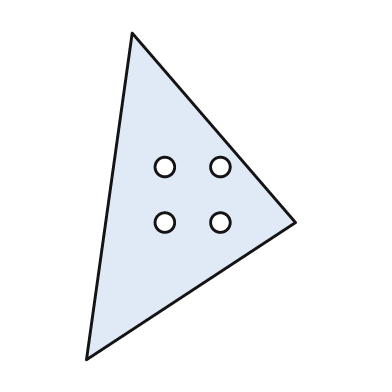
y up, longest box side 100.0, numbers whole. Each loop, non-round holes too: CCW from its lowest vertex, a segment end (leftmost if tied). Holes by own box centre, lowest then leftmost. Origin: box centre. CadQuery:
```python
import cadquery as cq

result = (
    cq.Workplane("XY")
    .moveTo(-32.0, -50.0)
    .lineTo(32.0, -8.0)
    .lineTo(-18.0, 50.0)
    .close()
    .moveTo(-8.0, -8.0)
    .circle(3.0)
    .moveTo(9.0, -8.0)
    .circle(3.0)
    .moveTo(-8.0, 9.0)
    .circle(3.0)
    .moveTo(9.0, 9.0)
    .circle(3.0)
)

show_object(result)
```